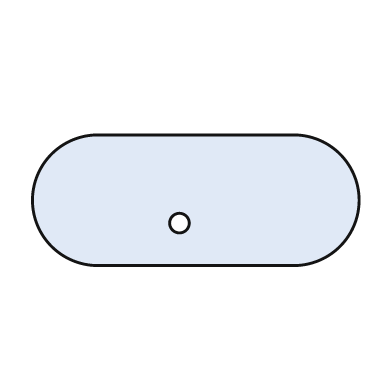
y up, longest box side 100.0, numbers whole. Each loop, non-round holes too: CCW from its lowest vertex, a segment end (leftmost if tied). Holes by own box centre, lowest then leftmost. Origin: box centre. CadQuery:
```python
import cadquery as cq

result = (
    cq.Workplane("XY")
    .moveTo(-30.0, -20.0)
    .lineTo(30.0, -20.0)
    .threePointArc((50.0, 0.0), (30.0, 20.0))
    .lineTo(-30.0, 20.0)
    .threePointArc((-50.0, 0.0), (-30.0, -20.0))
    .close()
    .moveTo(-5.0, -7.0)
    .circle(3.0)
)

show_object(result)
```